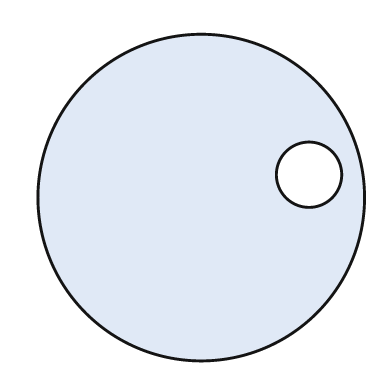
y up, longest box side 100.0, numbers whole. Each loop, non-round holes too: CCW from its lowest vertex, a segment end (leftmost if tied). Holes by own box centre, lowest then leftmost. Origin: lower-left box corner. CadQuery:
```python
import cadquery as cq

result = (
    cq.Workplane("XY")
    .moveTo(50.0, 50.0)
    .circle(50.0)
    .moveTo(83.0, 57.0)
    .circle(10.0)
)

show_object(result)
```